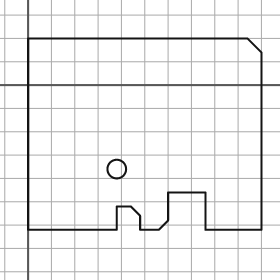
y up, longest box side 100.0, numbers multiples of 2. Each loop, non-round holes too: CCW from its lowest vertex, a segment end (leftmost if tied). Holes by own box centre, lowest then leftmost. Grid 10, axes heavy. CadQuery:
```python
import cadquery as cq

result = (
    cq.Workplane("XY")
    .moveTo(0.0, -62.0)
    .lineTo(38.0, -62.0)
    .lineTo(38.0, -52.0)
    .lineTo(44.0, -52.0)
    .lineTo(48.0, -56.0)
    .lineTo(48.0, -62.0)
    .lineTo(56.0, -62.0)
    .lineTo(60.0, -58.0)
    .lineTo(60.0, -46.0)
    .lineTo(76.0, -46.0)
    .lineTo(76.0, -62.0)
    .lineTo(100.0, -62.0)
    .lineTo(100.0, 14.0)
    .lineTo(94.0, 20.0)
    .lineTo(0.0, 20.0)
    .close()
    .moveTo(38.0, -36.0)
    .circle(4.0)
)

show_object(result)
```